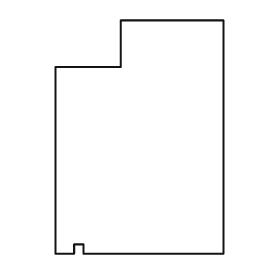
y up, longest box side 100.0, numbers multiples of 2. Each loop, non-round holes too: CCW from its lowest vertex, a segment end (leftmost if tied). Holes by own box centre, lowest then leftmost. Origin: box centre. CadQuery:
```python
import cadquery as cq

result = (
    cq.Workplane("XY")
    .moveTo(-36.0, -50.0)
    .lineTo(-28.0, -50.0)
    .lineTo(-28.0, -46.0)
    .lineTo(-24.0, -46.0)
    .lineTo(-24.0, -50.0)
    .lineTo(36.0, -50.0)
    .lineTo(36.0, 50.0)
    .lineTo(-8.0, 50.0)
    .lineTo(-8.0, 30.0)
    .lineTo(-36.0, 30.0)
    .close()
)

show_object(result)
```